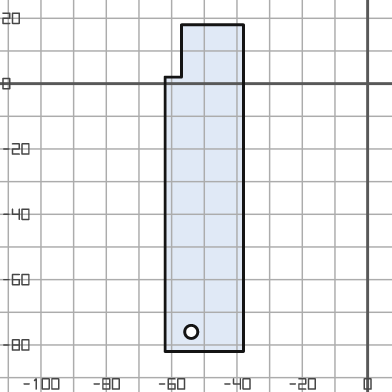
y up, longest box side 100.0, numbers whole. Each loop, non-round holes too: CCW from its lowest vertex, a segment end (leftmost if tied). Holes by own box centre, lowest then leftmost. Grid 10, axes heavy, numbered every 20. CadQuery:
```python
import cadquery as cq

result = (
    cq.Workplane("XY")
    .moveTo(-62.0, -82.0)
    .lineTo(-38.0, -82.0)
    .lineTo(-38.0, 18.0)
    .lineTo(-57.0, 18.0)
    .lineTo(-57.0, 2.0)
    .lineTo(-62.0, 2.0)
    .close()
    .moveTo(-54.0, -76.0)
    .circle(2.0)
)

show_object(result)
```